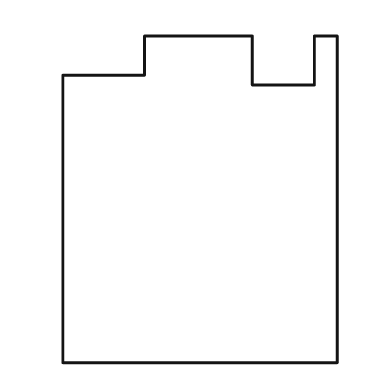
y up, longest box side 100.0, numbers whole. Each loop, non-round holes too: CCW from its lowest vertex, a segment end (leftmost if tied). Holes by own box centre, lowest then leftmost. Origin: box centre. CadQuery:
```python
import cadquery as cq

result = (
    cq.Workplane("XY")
    .moveTo(-42.0, -50.0)
    .lineTo(42.0, -50.0)
    .lineTo(42.0, 50.0)
    .lineTo(35.0, 50.0)
    .lineTo(35.0, 35.0)
    .lineTo(16.0, 35.0)
    .lineTo(16.0, 50.0)
    .lineTo(-17.0, 50.0)
    .lineTo(-17.0, 38.0)
    .lineTo(-42.0, 38.0)
    .close()
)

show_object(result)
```